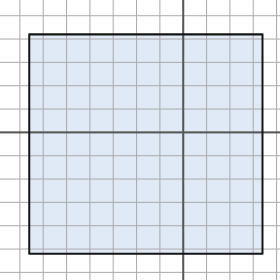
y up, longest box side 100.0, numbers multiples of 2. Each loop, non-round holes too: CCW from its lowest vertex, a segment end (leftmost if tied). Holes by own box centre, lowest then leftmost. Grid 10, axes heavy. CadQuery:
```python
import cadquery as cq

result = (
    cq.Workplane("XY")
    .moveTo(-66.0, -52.0)
    .lineTo(34.0, -52.0)
    .lineTo(34.0, 42.0)
    .lineTo(-66.0, 42.0)
    .close()
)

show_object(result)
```